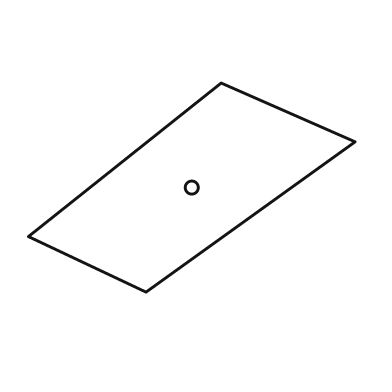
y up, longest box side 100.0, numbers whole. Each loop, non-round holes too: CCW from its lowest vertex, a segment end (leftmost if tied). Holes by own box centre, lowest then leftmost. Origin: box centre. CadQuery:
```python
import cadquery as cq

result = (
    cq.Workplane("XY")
    .moveTo(-14.0, -32.0)
    .lineTo(50.0, 14.0)
    .lineTo(9.0, 32.0)
    .lineTo(-50.0, -15.0)
    .close()
    .moveTo(0.0, 0.0)
    .circle(2.0)
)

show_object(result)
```